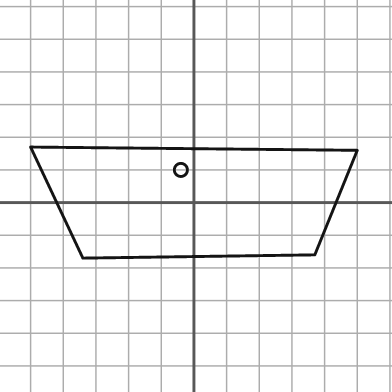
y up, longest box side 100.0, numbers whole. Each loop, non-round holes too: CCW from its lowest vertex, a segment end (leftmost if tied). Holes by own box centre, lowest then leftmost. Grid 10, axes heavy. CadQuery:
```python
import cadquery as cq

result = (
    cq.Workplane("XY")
    .moveTo(-34.0, -17.0)
    .lineTo(37.0, -16.0)
    .lineTo(50.0, 16.0)
    .lineTo(-50.0, 17.0)
    .close()
    .moveTo(-4.0, 10.0)
    .circle(2.0)
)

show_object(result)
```